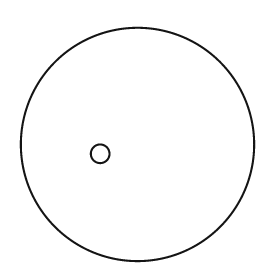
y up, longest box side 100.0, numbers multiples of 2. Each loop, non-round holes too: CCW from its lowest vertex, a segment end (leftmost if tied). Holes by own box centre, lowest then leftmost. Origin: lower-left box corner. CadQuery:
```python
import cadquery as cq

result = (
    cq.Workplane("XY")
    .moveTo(50.0, 50.0)
    .circle(50.0)
    .moveTo(34.0, 46.0)
    .circle(4.0)
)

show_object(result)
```